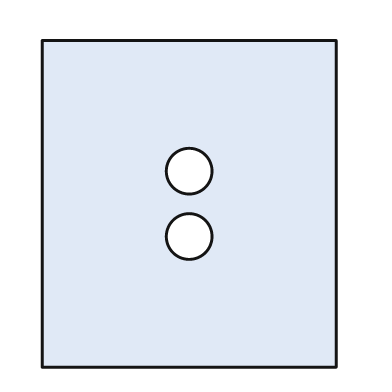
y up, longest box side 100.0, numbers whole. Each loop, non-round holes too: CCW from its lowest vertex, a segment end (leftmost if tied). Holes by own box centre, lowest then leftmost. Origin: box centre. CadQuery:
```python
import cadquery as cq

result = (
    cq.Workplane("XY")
    .moveTo(-45.0, -50.0)
    .lineTo(45.0, -50.0)
    .lineTo(45.0, 50.0)
    .lineTo(-45.0, 50.0)
    .close()
    .moveTo(0.0, -10.0)
    .circle(7.0)
    .moveTo(0.0, 10.0)
    .circle(7.0)
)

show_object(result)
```